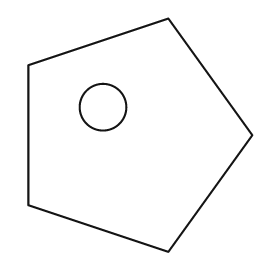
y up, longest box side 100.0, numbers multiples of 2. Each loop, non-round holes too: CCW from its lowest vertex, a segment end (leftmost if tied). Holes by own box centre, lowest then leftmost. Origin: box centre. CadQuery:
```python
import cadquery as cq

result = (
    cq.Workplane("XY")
    .moveTo(12.0, -50.0)
    .lineTo(48.0, 0.0)
    .lineTo(12.0, 50.0)
    .lineTo(-48.0, 30.0)
    .lineTo(-48.0, -30.0)
    .close()
    .moveTo(-16.0, 12.0)
    .circle(10.0)
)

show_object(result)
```